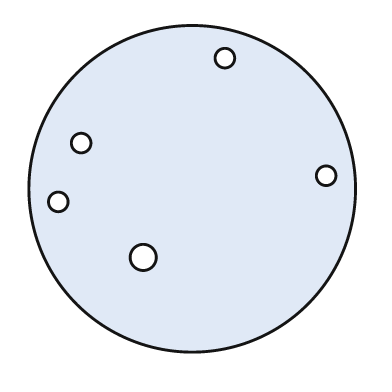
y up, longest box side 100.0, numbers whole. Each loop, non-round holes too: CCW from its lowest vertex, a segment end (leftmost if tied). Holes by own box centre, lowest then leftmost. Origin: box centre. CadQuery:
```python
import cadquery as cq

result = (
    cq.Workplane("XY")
    .moveTo(0.0, 0.0)
    .circle(50.0)
    .moveTo(-15.0, -21.0)
    .circle(4.0)
    .moveTo(-41.0, -4.0)
    .circle(3.0)
    .moveTo(41.0, 4.0)
    .circle(3.0)
    .moveTo(-34.0, 14.0)
    .circle(3.0)
    .moveTo(10.0, 40.0)
    .circle(3.0)
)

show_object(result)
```